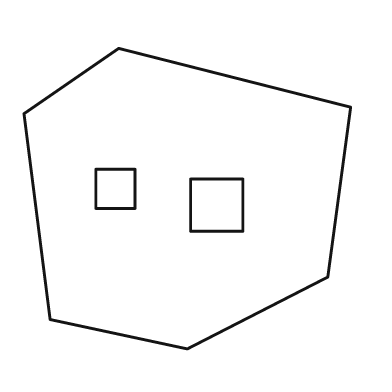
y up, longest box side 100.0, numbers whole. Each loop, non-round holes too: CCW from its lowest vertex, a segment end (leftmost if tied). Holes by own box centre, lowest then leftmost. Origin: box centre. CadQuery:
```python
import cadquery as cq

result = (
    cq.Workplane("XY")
    .moveTo(0.0, -46.0)
    .lineTo(43.0, -24.0)
    .lineTo(50.0, 28.0)
    .lineTo(-21.0, 46.0)
    .lineTo(-50.0, 26.0)
    .lineTo(-42.0, -37.0)
    .close()
    .moveTo(1.0, -10.0)
    .lineTo(17.0, -10.0)
    .lineTo(17.0, 6.0)
    .lineTo(1.0, 6.0)
    .close()
    .moveTo(-28.0, -3.0)
    .lineTo(-16.0, -3.0)
    .lineTo(-16.0, 9.0)
    .lineTo(-28.0, 9.0)
    .close()
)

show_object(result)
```